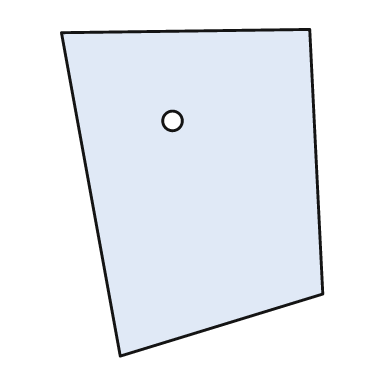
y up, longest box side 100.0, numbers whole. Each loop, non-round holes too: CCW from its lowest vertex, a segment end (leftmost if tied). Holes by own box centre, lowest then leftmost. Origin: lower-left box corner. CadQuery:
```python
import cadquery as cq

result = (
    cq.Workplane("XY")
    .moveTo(18.0, 0.0)
    .lineTo(80.0, 19.0)
    .lineTo(76.0, 100.0)
    .lineTo(0.0, 99.0)
    .close()
    .moveTo(34.0, 72.0)
    .circle(3.0)
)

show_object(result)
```